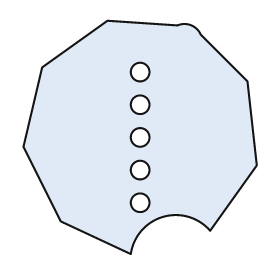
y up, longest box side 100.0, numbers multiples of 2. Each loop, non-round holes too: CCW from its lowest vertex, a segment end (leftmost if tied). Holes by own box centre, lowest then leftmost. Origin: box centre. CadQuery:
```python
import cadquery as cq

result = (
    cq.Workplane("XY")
    .moveTo(-4.0, -50.0)
    .threePointArc((10.0, -34.0), (30.0, -40.0))
    .lineTo(50.0, -12.0)
    .lineTo(46.0, 24.0)
    .lineTo(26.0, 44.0)
    .threePointArc((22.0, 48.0), (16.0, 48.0))
    .lineTo(-14.0, 50.0)
    .lineTo(-42.0, 30.0)
    .lineTo(-50.0, -4.0)
    .lineTo(-34.0, -36.0)
    .close()
    .moveTo(0.0, -28.0)
    .circle(4.0)
    .moveTo(0.0, -14.0)
    .circle(4.0)
    .moveTo(0.0, 0.0)
    .circle(4.0)
    .moveTo(0.0, 14.0)
    .circle(4.0)
    .moveTo(0.0, 28.0)
    .circle(4.0)
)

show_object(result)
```